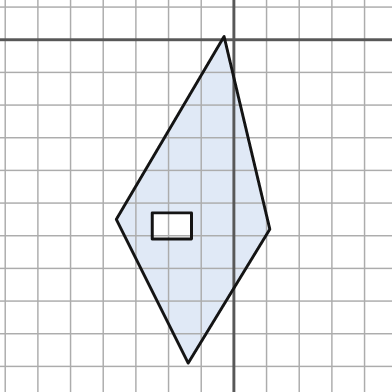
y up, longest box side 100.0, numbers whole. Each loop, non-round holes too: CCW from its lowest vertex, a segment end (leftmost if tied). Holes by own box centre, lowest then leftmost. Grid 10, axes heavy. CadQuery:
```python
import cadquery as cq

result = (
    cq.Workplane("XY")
    .moveTo(-14.0, -99.0)
    .lineTo(11.0, -58.0)
    .lineTo(-3.0, 1.0)
    .lineTo(-36.0, -55.0)
    .close()
    .moveTo(-25.0, -61.0)
    .lineTo(-13.0, -61.0)
    .lineTo(-13.0, -53.0)
    .lineTo(-25.0, -53.0)
    .close()
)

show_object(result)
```